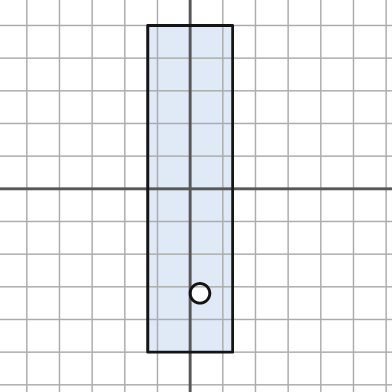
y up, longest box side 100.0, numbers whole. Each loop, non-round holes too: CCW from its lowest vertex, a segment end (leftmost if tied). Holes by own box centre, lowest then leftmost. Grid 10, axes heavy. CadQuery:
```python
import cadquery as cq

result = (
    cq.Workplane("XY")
    .moveTo(-13.0, -50.0)
    .lineTo(13.0, -50.0)
    .lineTo(13.0, 50.0)
    .lineTo(-13.0, 50.0)
    .close()
    .moveTo(3.0, -32.0)
    .circle(3.0)
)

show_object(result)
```